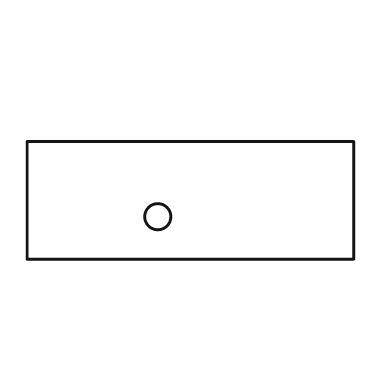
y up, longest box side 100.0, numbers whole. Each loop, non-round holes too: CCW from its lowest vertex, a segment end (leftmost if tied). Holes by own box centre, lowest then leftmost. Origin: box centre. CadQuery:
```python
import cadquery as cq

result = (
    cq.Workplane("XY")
    .moveTo(-50.0, -18.0)
    .lineTo(50.0, -18.0)
    .lineTo(50.0, 18.0)
    .lineTo(-50.0, 18.0)
    .close()
    .moveTo(-10.0, -5.0)
    .circle(4.0)
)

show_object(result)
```